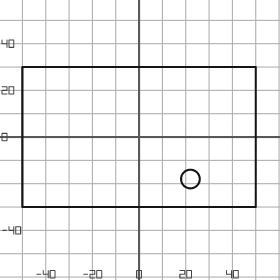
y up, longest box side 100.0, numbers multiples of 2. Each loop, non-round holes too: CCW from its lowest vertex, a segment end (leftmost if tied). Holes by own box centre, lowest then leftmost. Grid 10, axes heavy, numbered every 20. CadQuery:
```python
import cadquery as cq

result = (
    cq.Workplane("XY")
    .moveTo(-50.0, -30.0)
    .lineTo(50.0, -30.0)
    .lineTo(50.0, 30.0)
    .lineTo(-50.0, 30.0)
    .close()
    .moveTo(22.0, -18.0)
    .circle(4.0)
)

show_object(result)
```